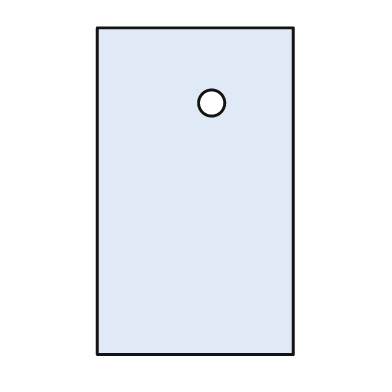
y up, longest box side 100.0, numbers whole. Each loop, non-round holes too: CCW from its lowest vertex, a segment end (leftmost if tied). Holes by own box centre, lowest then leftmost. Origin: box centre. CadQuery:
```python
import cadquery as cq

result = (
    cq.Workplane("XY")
    .moveTo(-30.0, -50.0)
    .lineTo(30.0, -50.0)
    .lineTo(30.0, 50.0)
    .lineTo(-30.0, 50.0)
    .close()
    .moveTo(5.0, 27.0)
    .circle(4.0)
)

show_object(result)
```